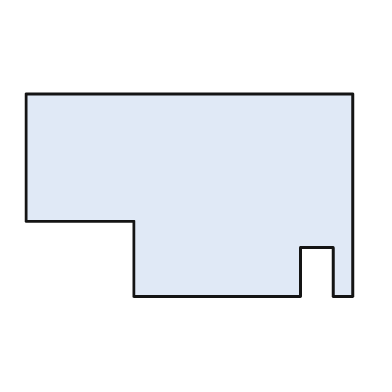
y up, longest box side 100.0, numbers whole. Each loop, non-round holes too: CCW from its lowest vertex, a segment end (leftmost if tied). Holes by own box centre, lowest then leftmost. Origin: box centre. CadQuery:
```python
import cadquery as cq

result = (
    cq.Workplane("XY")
    .moveTo(-17.0, -31.0)
    .lineTo(34.0, -31.0)
    .lineTo(34.0, -16.0)
    .lineTo(44.0, -16.0)
    .lineTo(44.0, -31.0)
    .lineTo(50.0, -31.0)
    .lineTo(50.0, 31.0)
    .lineTo(-50.0, 31.0)
    .lineTo(-50.0, -8.0)
    .lineTo(-17.0, -8.0)
    .close()
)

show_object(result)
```